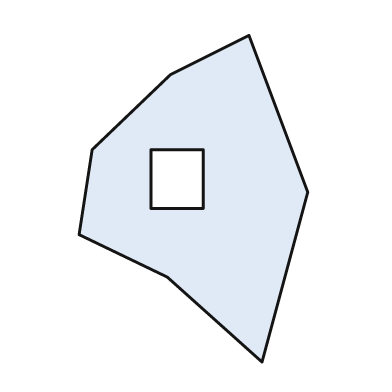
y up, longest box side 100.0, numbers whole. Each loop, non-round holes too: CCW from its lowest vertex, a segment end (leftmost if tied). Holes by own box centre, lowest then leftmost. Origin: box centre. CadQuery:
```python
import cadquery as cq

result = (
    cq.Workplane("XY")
    .moveTo(21.0, -50.0)
    .lineTo(35.0, 2.0)
    .lineTo(17.0, 50.0)
    .lineTo(-7.0, 38.0)
    .lineTo(-31.0, 15.0)
    .lineTo(-35.0, -11.0)
    .lineTo(-8.0, -24.0)
    .close()
    .moveTo(-13.0, -3.0)
    .lineTo(3.0, -3.0)
    .lineTo(3.0, 15.0)
    .lineTo(-13.0, 15.0)
    .close()
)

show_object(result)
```